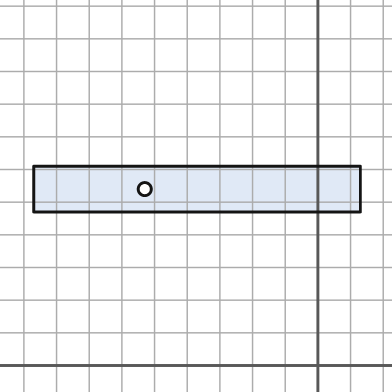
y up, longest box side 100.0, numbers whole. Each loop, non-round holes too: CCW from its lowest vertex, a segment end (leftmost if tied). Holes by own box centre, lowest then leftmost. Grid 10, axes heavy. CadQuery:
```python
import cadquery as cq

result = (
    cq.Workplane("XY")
    .moveTo(-87.0, 47.0)
    .lineTo(13.0, 47.0)
    .lineTo(13.0, 61.0)
    .lineTo(-87.0, 61.0)
    .close()
    .moveTo(-53.0, 54.0)
    .circle(2.0)
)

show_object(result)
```